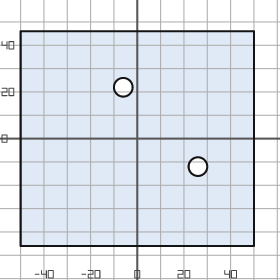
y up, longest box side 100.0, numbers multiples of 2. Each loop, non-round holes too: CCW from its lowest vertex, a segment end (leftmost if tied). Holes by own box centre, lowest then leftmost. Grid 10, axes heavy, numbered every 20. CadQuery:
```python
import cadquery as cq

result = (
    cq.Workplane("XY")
    .moveTo(-50.0, -46.0)
    .lineTo(50.0, -46.0)
    .lineTo(50.0, 46.0)
    .lineTo(-50.0, 46.0)
    .close()
    .moveTo(26.0, -12.0)
    .circle(4.0)
    .moveTo(-6.0, 22.0)
    .circle(4.0)
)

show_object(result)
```